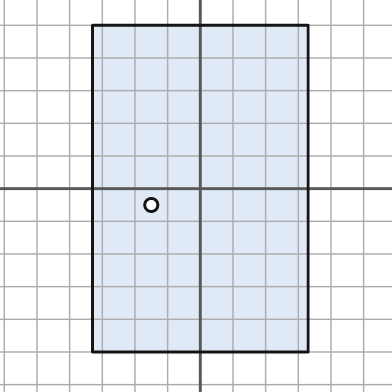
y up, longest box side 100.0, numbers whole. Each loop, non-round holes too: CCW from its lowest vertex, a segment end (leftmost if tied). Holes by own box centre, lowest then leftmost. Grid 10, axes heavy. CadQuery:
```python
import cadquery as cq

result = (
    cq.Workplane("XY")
    .moveTo(-33.0, -50.0)
    .lineTo(33.0, -50.0)
    .lineTo(33.0, 50.0)
    .lineTo(-33.0, 50.0)
    .close()
    .moveTo(-15.0, -5.0)
    .circle(2.0)
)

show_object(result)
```